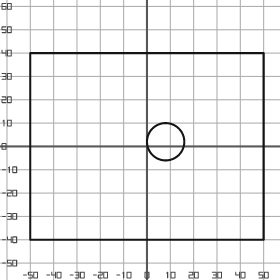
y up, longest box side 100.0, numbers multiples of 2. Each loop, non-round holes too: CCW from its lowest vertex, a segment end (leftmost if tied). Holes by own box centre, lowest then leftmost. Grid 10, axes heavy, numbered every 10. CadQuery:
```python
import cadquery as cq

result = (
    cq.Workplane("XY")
    .moveTo(-50.0, -40.0)
    .lineTo(50.0, -40.0)
    .lineTo(50.0, 40.0)
    .lineTo(-50.0, 40.0)
    .close()
    .moveTo(8.0, 2.0)
    .circle(8.0)
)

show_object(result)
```